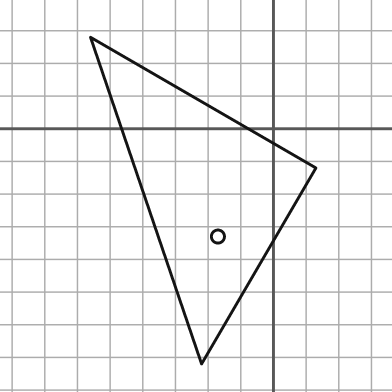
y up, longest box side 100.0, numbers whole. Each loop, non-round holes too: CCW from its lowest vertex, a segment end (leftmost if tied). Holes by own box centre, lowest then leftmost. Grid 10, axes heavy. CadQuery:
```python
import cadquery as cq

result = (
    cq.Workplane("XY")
    .moveTo(-22.0, -72.0)
    .lineTo(13.0, -12.0)
    .lineTo(-56.0, 28.0)
    .close()
    .moveTo(-17.0, -33.0)
    .circle(2.0)
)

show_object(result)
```